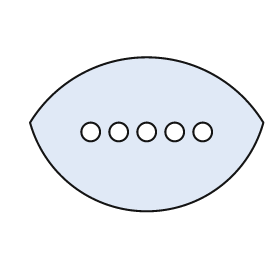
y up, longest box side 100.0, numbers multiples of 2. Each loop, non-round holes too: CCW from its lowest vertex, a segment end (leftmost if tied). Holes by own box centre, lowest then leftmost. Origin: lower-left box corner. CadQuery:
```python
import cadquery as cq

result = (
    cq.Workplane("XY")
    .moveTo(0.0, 38.0)
    .threePointArc((50.0, 0.0), (100.0, 38.0))
    .threePointArc((50.0, 66.0), (0.0, 38.0))
    .close()
    .moveTo(26.0, 34.0)
    .circle(4.0)
    .moveTo(38.0, 34.0)
    .circle(4.0)
    .moveTo(50.0, 34.0)
    .circle(4.0)
    .moveTo(62.0, 34.0)
    .circle(4.0)
    .moveTo(74.0, 34.0)
    .circle(4.0)
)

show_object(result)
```